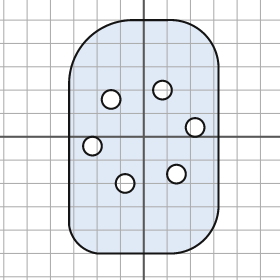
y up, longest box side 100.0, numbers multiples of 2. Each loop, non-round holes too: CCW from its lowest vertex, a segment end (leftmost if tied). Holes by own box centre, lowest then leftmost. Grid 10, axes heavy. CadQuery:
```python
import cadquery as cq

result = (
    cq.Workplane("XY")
    .moveTo(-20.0, -50.0)
    .lineTo(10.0, -50.0)
    .threePointArc((26.0, -44.0), (32.0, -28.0))
    .lineTo(32.0, 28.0)
    .threePointArc((26.0, 44.0), (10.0, 50.0))
    .lineTo(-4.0, 50.0)
    .threePointArc((-24.0, 42.0), (-32.0, 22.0))
    .lineTo(-32.0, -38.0)
    .threePointArc((-28.0, -46.0), (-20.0, -50.0))
    .close()
    .moveTo(-8.0, -20.0)
    .circle(4.0)
    .moveTo(14.0, -16.0)
    .circle(4.0)
    .moveTo(-22.0, -4.0)
    .circle(4.0)
    .moveTo(22.0, 4.0)
    .circle(4.0)
    .moveTo(-14.0, 16.0)
    .circle(4.0)
    .moveTo(8.0, 20.0)
    .circle(4.0)
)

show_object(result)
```